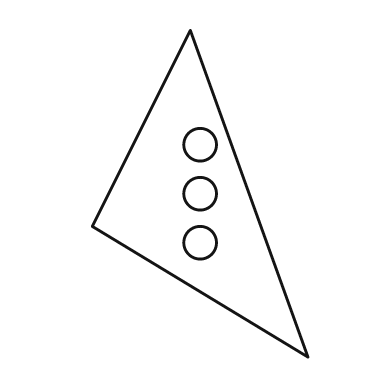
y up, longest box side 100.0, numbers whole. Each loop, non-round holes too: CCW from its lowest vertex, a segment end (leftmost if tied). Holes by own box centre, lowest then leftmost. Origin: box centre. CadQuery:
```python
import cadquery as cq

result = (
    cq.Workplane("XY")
    .moveTo(33.0, -50.0)
    .lineTo(-3.0, 50.0)
    .lineTo(-33.0, -10.0)
    .close()
    .moveTo(0.0, -15.0)
    .circle(5.0)
    .moveTo(0.0, 0.0)
    .circle(5.0)
    .moveTo(0.0, 15.0)
    .circle(5.0)
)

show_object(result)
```